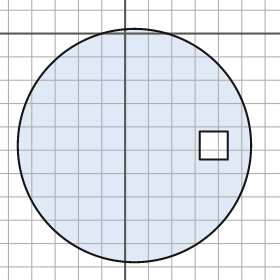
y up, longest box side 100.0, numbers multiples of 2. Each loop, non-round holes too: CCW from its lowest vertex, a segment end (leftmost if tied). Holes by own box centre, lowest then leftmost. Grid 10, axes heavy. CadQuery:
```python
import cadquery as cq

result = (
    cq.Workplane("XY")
    .moveTo(4.0, -48.0)
    .circle(50.0)
    .moveTo(32.0, -54.0)
    .lineTo(44.0, -54.0)
    .lineTo(44.0, -42.0)
    .lineTo(32.0, -42.0)
    .close()
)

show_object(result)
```